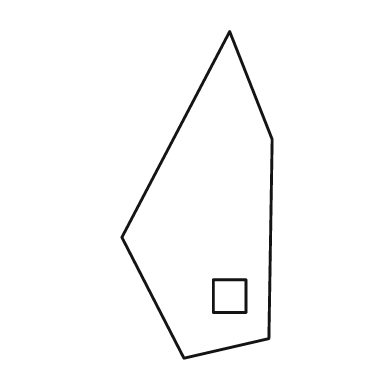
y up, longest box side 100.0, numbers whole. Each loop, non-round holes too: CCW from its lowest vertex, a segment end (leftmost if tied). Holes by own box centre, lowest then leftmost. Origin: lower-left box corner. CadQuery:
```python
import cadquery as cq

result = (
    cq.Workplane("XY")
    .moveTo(19.0, 0.0)
    .lineTo(45.0, 6.0)
    .lineTo(46.0, 67.0)
    .lineTo(33.0, 100.0)
    .lineTo(0.0, 37.0)
    .close()
    .moveTo(28.0, 14.0)
    .lineTo(38.0, 14.0)
    .lineTo(38.0, 24.0)
    .lineTo(28.0, 24.0)
    .close()
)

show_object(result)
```